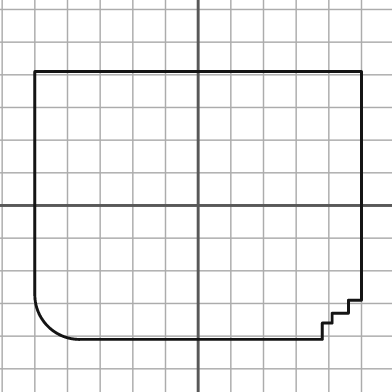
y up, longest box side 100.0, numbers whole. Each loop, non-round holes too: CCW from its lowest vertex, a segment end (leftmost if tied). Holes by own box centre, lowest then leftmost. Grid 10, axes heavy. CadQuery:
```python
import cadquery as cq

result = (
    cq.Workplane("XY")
    .moveTo(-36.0, -41.0)
    .lineTo(38.0, -41.0)
    .lineTo(38.0, -36.0)
    .lineTo(41.0, -36.0)
    .lineTo(41.0, -33.0)
    .lineTo(46.0, -33.0)
    .lineTo(46.0, -29.0)
    .lineTo(50.0, -29.0)
    .lineTo(50.0, 41.0)
    .lineTo(-50.0, 41.0)
    .lineTo(-50.0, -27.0)
    .threePointArc((-46.0, -37.0), (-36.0, -41.0))
    .close()
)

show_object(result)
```